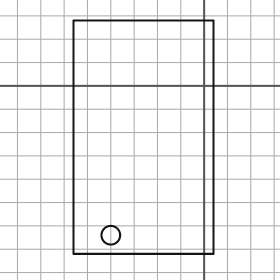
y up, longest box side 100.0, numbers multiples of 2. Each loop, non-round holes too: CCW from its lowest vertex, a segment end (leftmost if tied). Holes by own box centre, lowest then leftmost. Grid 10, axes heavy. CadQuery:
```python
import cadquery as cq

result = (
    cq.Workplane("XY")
    .moveTo(-56.0, -72.0)
    .lineTo(4.0, -72.0)
    .lineTo(4.0, 28.0)
    .lineTo(-56.0, 28.0)
    .close()
    .moveTo(-40.0, -64.0)
    .circle(4.0)
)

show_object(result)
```